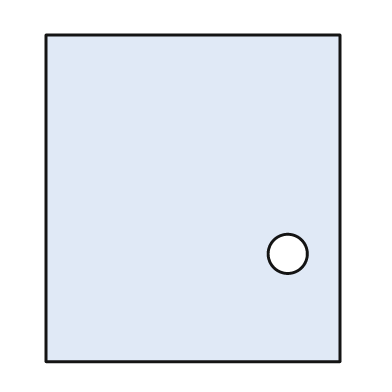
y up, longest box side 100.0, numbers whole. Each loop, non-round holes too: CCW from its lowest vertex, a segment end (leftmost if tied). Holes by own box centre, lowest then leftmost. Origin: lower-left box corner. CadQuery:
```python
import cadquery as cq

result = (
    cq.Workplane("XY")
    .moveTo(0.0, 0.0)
    .lineTo(90.0, 0.0)
    .lineTo(90.0, 100.0)
    .lineTo(0.0, 100.0)
    .close()
    .moveTo(74.0, 33.0)
    .circle(6.0)
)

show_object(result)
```